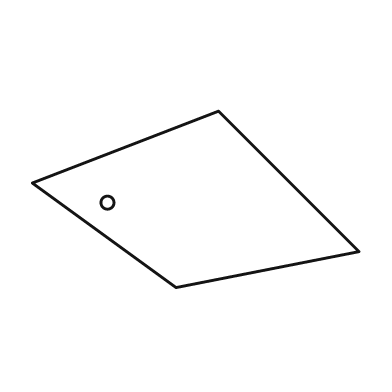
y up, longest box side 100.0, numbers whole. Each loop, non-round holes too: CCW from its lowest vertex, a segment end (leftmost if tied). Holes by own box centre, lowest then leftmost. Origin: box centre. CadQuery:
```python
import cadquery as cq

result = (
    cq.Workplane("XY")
    .moveTo(-6.0, -27.0)
    .lineTo(50.0, -16.0)
    .lineTo(7.0, 27.0)
    .lineTo(-50.0, 5.0)
    .close()
    .moveTo(-27.0, -1.0)
    .circle(2.0)
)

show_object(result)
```